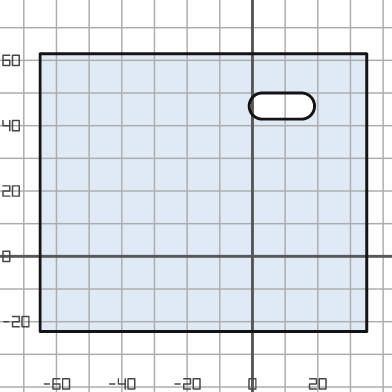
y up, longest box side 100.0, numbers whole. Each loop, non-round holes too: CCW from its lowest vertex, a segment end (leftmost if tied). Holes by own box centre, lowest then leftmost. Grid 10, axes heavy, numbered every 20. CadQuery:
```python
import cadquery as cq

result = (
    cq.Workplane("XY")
    .moveTo(-65.0, -23.0)
    .lineTo(35.0, -23.0)
    .lineTo(35.0, 62.0)
    .lineTo(-65.0, 62.0)
    .close()
    .moveTo(3.0, 42.0)
    .lineTo(15.0, 42.0)
    .threePointArc((19.0, 46.0), (15.0, 50.0))
    .lineTo(3.0, 50.0)
    .threePointArc((-1.0, 46.0), (3.0, 42.0))
    .close()
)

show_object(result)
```